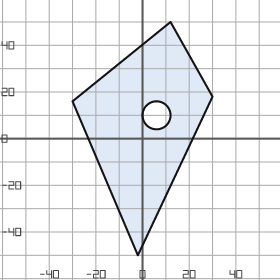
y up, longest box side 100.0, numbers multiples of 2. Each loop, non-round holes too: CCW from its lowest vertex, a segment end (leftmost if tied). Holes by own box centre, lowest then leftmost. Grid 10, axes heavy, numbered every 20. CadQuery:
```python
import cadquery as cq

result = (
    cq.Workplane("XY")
    .moveTo(-2.0, -50.0)
    .lineTo(30.0, 18.0)
    .lineTo(12.0, 50.0)
    .lineTo(-30.0, 16.0)
    .close()
    .moveTo(6.0, 10.0)
    .circle(6.0)
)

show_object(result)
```